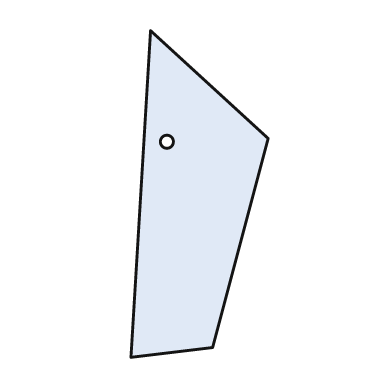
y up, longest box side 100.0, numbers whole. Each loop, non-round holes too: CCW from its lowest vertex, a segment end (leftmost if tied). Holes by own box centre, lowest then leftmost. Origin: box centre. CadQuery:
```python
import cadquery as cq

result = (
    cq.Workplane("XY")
    .moveTo(-21.0, -50.0)
    .lineTo(4.0, -47.0)
    .lineTo(21.0, 17.0)
    .lineTo(-15.0, 50.0)
    .close()
    .moveTo(-10.0, 16.0)
    .circle(2.0)
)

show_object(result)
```